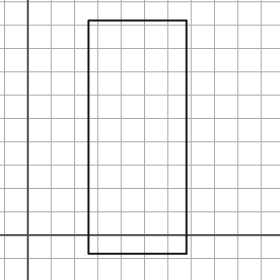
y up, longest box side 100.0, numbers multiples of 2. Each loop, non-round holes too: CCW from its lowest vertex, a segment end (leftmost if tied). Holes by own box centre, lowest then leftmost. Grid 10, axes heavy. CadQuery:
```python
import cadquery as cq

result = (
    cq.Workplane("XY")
    .moveTo(26.0, -8.0)
    .lineTo(68.0, -8.0)
    .lineTo(68.0, 92.0)
    .lineTo(26.0, 92.0)
    .close()
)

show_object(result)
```